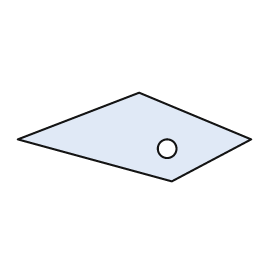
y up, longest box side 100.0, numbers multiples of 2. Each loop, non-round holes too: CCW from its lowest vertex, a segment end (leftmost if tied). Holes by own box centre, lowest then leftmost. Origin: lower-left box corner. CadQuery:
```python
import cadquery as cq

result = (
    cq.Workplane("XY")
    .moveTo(66.0, 0.0)
    .lineTo(100.0, 18.0)
    .lineTo(52.0, 38.0)
    .lineTo(0.0, 18.0)
    .close()
    .moveTo(64.0, 14.0)
    .circle(4.0)
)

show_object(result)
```